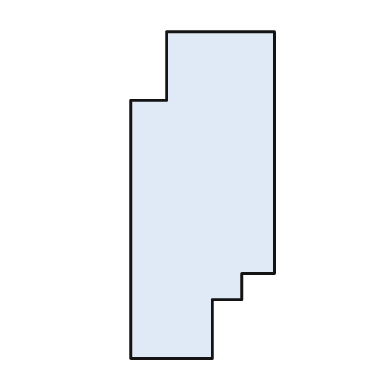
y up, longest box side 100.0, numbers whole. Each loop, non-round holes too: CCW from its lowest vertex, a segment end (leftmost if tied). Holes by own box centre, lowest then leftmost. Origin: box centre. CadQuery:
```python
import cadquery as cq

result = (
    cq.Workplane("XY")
    .moveTo(-22.0, -50.0)
    .lineTo(3.0, -50.0)
    .lineTo(3.0, -32.0)
    .lineTo(12.0, -32.0)
    .lineTo(12.0, -24.0)
    .lineTo(22.0, -24.0)
    .lineTo(22.0, 50.0)
    .lineTo(-11.0, 50.0)
    .lineTo(-11.0, 29.0)
    .lineTo(-22.0, 29.0)
    .close()
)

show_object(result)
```